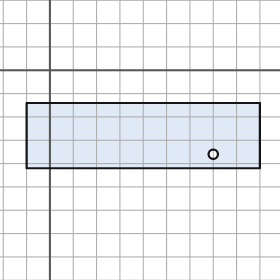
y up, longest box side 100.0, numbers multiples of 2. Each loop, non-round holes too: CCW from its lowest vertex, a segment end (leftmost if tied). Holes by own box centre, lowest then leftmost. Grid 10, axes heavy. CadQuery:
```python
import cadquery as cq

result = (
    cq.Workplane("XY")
    .moveTo(-10.0, -42.0)
    .lineTo(90.0, -42.0)
    .lineTo(90.0, -14.0)
    .lineTo(-10.0, -14.0)
    .close()
    .moveTo(70.0, -36.0)
    .circle(2.0)
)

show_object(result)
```